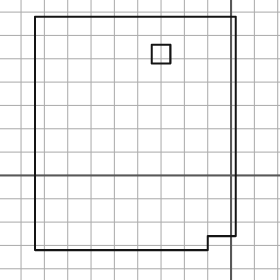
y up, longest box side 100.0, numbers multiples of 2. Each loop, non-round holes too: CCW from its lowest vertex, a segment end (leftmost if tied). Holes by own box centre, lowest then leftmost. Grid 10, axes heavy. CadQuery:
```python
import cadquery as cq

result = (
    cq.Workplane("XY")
    .moveTo(-84.0, -32.0)
    .lineTo(-10.0, -32.0)
    .lineTo(-10.0, -26.0)
    .lineTo(2.0, -26.0)
    .lineTo(2.0, 68.0)
    .lineTo(-84.0, 68.0)
    .close()
    .moveTo(-34.0, 48.0)
    .lineTo(-26.0, 48.0)
    .lineTo(-26.0, 56.0)
    .lineTo(-34.0, 56.0)
    .close()
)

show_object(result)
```